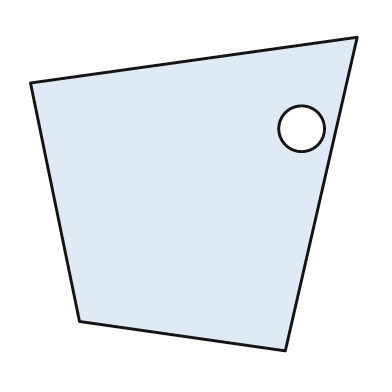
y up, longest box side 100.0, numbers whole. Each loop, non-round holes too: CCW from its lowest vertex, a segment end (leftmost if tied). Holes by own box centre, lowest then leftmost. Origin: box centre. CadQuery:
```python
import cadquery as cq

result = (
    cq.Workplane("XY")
    .moveTo(28.0, -48.0)
    .lineTo(50.0, 48.0)
    .lineTo(-50.0, 34.0)
    .lineTo(-35.0, -39.0)
    .close()
    .moveTo(33.0, 20.0)
    .circle(7.0)
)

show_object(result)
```